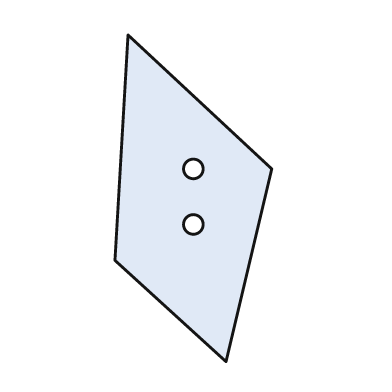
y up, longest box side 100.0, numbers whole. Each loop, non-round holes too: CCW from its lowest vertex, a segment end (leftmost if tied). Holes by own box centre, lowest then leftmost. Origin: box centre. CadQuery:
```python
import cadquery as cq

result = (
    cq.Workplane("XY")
    .moveTo(10.0, -50.0)
    .lineTo(24.0, 9.0)
    .lineTo(-20.0, 50.0)
    .lineTo(-24.0, -19.0)
    .close()
    .moveTo(0.0, -8.0)
    .circle(3.0)
    .moveTo(0.0, 9.0)
    .circle(3.0)
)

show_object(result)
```